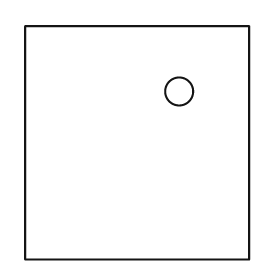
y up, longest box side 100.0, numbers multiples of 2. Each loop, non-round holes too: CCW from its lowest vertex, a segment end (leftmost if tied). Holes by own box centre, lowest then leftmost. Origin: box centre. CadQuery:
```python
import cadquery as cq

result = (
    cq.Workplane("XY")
    .moveTo(-48.0, -50.0)
    .lineTo(48.0, -50.0)
    .lineTo(48.0, 50.0)
    .lineTo(-48.0, 50.0)
    .close()
    .moveTo(18.0, 22.0)
    .circle(6.0)
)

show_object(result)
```